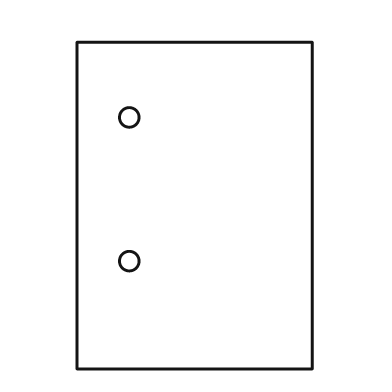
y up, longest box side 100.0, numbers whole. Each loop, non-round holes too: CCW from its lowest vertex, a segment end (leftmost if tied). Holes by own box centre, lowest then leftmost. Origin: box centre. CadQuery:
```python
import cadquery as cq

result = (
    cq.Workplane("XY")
    .moveTo(-36.0, -50.0)
    .lineTo(36.0, -50.0)
    .lineTo(36.0, 50.0)
    .lineTo(-36.0, 50.0)
    .close()
    .moveTo(-20.0, -17.0)
    .circle(3.0)
    .moveTo(-20.0, 27.0)
    .circle(3.0)
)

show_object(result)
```